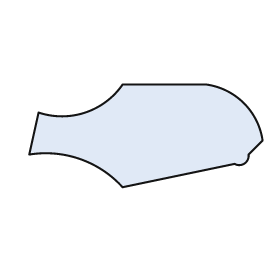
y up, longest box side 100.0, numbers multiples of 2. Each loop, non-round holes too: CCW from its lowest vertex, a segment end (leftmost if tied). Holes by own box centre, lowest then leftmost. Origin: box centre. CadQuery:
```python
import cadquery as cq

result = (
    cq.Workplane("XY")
    .moveTo(-10.0, -22.0)
    .lineTo(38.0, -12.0)
    .threePointArc((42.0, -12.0), (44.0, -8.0))
    .lineTo(50.0, -2.0)
    .threePointArc((42.0, 14.0), (26.0, 22.0))
    .lineTo(-10.0, 22.0)
    .threePointArc((-26.0, 10.0), (-46.0, 10.0))
    .lineTo(-50.0, -8.0)
    .threePointArc((-28.0, -10.0), (-10.0, -22.0))
    .close()
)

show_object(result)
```